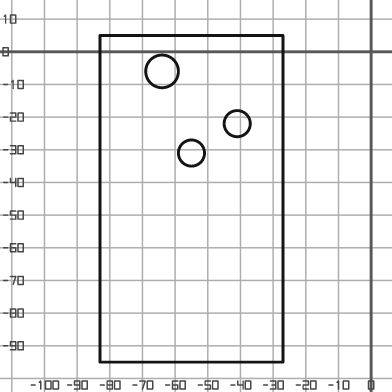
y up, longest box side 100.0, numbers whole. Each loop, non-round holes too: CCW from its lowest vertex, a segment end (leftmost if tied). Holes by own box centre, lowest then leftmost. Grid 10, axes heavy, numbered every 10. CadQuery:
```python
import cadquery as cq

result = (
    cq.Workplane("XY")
    .moveTo(-83.0, -95.0)
    .lineTo(-27.0, -95.0)
    .lineTo(-27.0, 5.0)
    .lineTo(-83.0, 5.0)
    .close()
    .moveTo(-55.0, -31.0)
    .circle(4.0)
    .moveTo(-41.0, -22.0)
    .circle(4.0)
    .moveTo(-64.0, -6.0)
    .circle(5.0)
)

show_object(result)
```